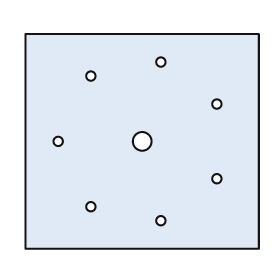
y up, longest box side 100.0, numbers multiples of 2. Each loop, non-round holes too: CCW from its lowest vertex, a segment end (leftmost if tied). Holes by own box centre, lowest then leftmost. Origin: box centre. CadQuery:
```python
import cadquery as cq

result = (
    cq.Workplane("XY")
    .moveTo(-50.0, -46.0)
    .lineTo(50.0, -46.0)
    .lineTo(50.0, 46.0)
    .lineTo(-50.0, 46.0)
    .close()
    .moveTo(8.0, -34.0)
    .circle(2.0)
    .moveTo(-22.0, -28.0)
    .circle(2.0)
    .moveTo(32.0, -16.0)
    .circle(2.0)
    .moveTo(-36.0, 0.0)
    .circle(2.0)
    .moveTo(0.0, 0.0)
    .circle(4.0)
    .moveTo(32.0, 16.0)
    .circle(2.0)
    .moveTo(-22.0, 28.0)
    .circle(2.0)
    .moveTo(8.0, 34.0)
    .circle(2.0)
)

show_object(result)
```